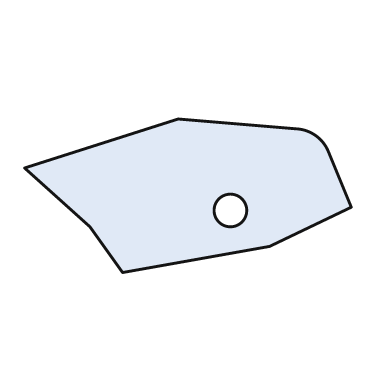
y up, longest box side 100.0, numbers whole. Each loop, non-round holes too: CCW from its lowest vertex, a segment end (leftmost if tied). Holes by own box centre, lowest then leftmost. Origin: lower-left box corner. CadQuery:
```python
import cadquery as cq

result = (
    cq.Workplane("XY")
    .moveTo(30.0, 0.0)
    .lineTo(75.0, 8.0)
    .lineTo(100.0, 20.0)
    .lineTo(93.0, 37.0)
    .threePointArc((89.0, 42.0), (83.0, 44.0))
    .lineTo(47.0, 47.0)
    .lineTo(0.0, 32.0)
    .lineTo(20.0, 14.0)
    .close()
    .moveTo(63.0, 19.0)
    .circle(5.0)
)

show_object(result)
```